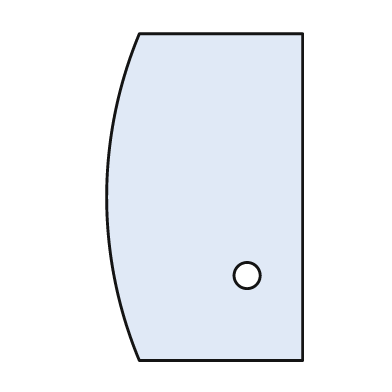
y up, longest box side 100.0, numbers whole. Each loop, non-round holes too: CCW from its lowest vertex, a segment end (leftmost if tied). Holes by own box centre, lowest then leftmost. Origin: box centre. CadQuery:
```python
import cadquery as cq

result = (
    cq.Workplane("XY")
    .moveTo(-20.0, -50.0)
    .lineTo(30.0, -50.0)
    .lineTo(30.0, 50.0)
    .lineTo(-20.0, 50.0)
    .threePointArc((-30.0, 0.0), (-20.0, -50.0))
    .close()
    .moveTo(13.0, -24.0)
    .circle(4.0)
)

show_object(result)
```